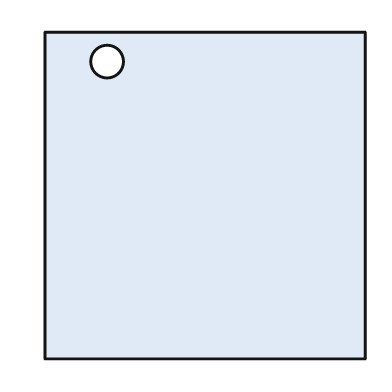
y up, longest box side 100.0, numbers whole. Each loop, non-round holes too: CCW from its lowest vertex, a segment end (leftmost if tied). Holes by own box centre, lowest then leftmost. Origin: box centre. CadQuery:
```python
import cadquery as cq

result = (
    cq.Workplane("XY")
    .moveTo(-49.0, -50.0)
    .lineTo(49.0, -50.0)
    .lineTo(49.0, 50.0)
    .lineTo(-49.0, 50.0)
    .close()
    .moveTo(-30.0, 41.0)
    .circle(5.0)
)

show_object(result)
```